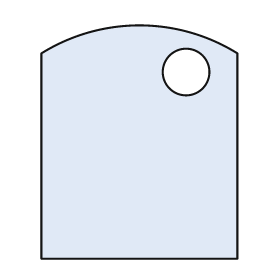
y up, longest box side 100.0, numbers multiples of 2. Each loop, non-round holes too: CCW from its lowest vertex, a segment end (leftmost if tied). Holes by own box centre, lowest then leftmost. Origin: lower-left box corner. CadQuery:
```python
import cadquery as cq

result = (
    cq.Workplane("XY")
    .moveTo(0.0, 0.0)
    .lineTo(84.0, 0.0)
    .lineTo(84.0, 88.0)
    .threePointArc((42.0, 100.0), (0.0, 88.0))
    .close()
    .moveTo(62.0, 80.0)
    .circle(10.0)
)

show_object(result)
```